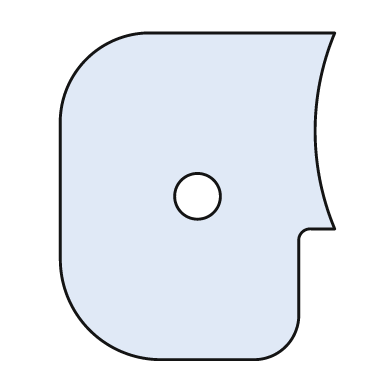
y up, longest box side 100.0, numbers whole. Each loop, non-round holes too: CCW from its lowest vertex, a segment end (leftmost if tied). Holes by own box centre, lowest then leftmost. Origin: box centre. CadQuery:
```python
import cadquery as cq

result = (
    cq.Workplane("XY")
    .moveTo(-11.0, -50.0)
    .lineTo(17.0, -50.0)
    .threePointArc((27.0, -46.0), (31.0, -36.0))
    .lineTo(31.0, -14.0)
    .threePointArc((32.0, -11.0), (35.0, -10.0))
    .lineTo(42.0, -10.0)
    .threePointArc((36.0, 20.0), (42.0, 50.0))
    .lineTo(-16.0, 50.0)
    .threePointArc((-34.0, 42.0), (-42.0, 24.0))
    .lineTo(-42.0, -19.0)
    .threePointArc((-33.0, -41.0), (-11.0, -50.0))
    .close()
    .moveTo(0.0, 0.0)
    .circle(7.0)
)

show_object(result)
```